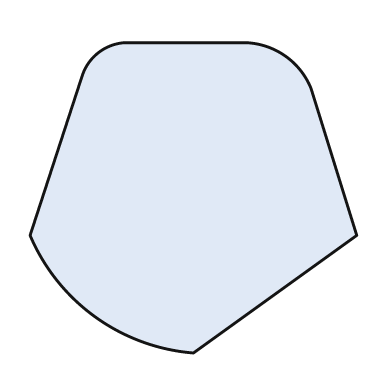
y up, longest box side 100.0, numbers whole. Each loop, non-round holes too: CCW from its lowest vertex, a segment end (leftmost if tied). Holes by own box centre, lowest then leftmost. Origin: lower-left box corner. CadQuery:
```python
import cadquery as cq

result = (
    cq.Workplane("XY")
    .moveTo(50.0, 0.0)
    .lineTo(100.0, 36.0)
    .lineTo(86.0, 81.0)
    .threePointArc((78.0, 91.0), (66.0, 95.0))
    .lineTo(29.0, 95.0)
    .threePointArc((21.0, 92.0), (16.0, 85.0))
    .lineTo(0.0, 36.0)
    .threePointArc((20.0, 11.0), (50.0, 0.0))
    .close()
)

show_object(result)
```